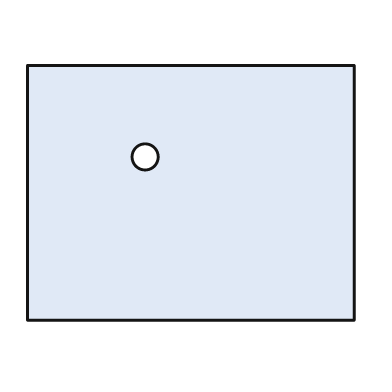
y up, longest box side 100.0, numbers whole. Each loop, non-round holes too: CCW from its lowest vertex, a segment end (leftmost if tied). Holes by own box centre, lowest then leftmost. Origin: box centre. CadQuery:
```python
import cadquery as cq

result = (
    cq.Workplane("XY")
    .moveTo(-50.0, -39.0)
    .lineTo(50.0, -39.0)
    .lineTo(50.0, 39.0)
    .lineTo(-50.0, 39.0)
    .close()
    .moveTo(-14.0, 11.0)
    .circle(4.0)
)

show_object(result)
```